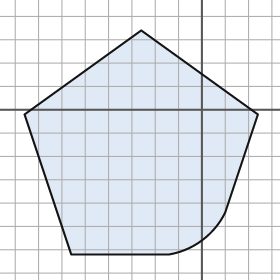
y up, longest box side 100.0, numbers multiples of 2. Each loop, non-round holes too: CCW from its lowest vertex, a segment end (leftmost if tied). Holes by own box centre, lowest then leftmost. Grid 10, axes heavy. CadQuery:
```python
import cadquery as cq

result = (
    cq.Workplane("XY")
    .moveTo(-56.0, -62.0)
    .lineTo(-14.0, -62.0)
    .threePointArc((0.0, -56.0), (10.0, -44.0))
    .lineTo(24.0, -2.0)
    .lineTo(-26.0, 34.0)
    .lineTo(-76.0, -2.0)
    .close()
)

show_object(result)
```